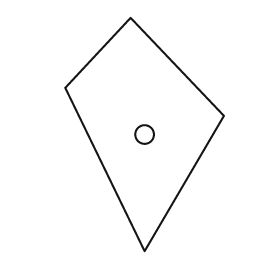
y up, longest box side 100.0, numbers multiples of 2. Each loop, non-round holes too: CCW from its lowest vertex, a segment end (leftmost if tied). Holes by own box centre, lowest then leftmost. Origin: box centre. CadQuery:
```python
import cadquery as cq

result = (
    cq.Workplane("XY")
    .moveTo(0.0, -50.0)
    .lineTo(34.0, 8.0)
    .lineTo(-6.0, 50.0)
    .lineTo(-34.0, 20.0)
    .close()
    .moveTo(0.0, 0.0)
    .circle(4.0)
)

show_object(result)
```